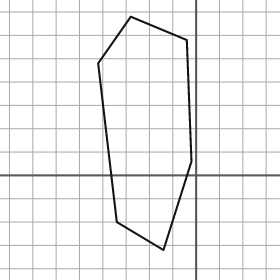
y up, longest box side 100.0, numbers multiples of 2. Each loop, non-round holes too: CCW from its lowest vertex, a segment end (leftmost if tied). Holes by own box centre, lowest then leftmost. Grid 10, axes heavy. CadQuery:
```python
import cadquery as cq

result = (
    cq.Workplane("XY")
    .moveTo(-14.0, -32.0)
    .lineTo(-2.0, 6.0)
    .lineTo(-4.0, 58.0)
    .lineTo(-28.0, 68.0)
    .lineTo(-42.0, 48.0)
    .lineTo(-34.0, -20.0)
    .close()
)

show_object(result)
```